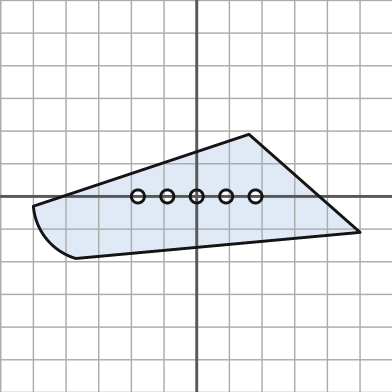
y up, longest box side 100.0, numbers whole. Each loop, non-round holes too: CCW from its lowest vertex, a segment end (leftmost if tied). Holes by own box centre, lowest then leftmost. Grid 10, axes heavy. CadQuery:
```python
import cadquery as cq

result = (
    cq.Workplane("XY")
    .moveTo(-37.0, -19.0)
    .lineTo(50.0, -11.0)
    .lineTo(16.0, 19.0)
    .lineTo(-50.0, -3.0)
    .threePointArc((-46.0, -13.0), (-37.0, -19.0))
    .close()
    .moveTo(-18.0, 0.0)
    .circle(2.0)
    .moveTo(-9.0, 0.0)
    .circle(2.0)
    .moveTo(0.0, 0.0)
    .circle(2.0)
    .moveTo(9.0, 0.0)
    .circle(2.0)
    .moveTo(18.0, 0.0)
    .circle(2.0)
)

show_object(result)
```